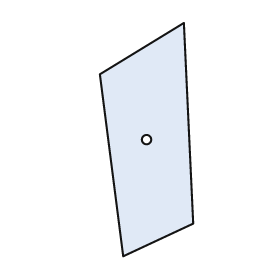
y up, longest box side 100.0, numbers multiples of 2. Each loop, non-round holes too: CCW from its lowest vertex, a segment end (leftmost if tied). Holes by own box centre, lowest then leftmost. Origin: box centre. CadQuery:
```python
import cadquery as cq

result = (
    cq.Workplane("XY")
    .moveTo(-10.0, -50.0)
    .lineTo(20.0, -36.0)
    .lineTo(16.0, 50.0)
    .lineTo(-20.0, 28.0)
    .close()
    .moveTo(0.0, 0.0)
    .circle(2.0)
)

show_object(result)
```